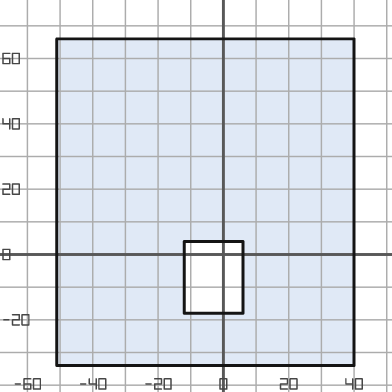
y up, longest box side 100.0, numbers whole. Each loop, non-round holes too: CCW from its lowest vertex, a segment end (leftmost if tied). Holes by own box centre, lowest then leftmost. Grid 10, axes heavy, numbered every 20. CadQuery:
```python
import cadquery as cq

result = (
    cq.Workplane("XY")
    .moveTo(-51.0, -34.0)
    .lineTo(40.0, -34.0)
    .lineTo(40.0, 66.0)
    .lineTo(-51.0, 66.0)
    .close()
    .moveTo(-12.0, -18.0)
    .lineTo(6.0, -18.0)
    .lineTo(6.0, 4.0)
    .lineTo(-12.0, 4.0)
    .close()
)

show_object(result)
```